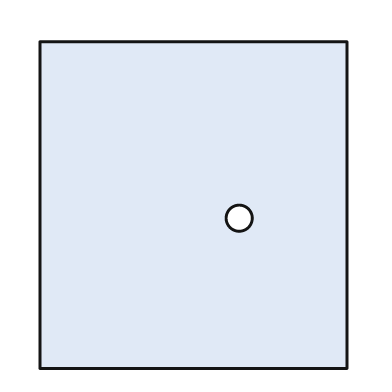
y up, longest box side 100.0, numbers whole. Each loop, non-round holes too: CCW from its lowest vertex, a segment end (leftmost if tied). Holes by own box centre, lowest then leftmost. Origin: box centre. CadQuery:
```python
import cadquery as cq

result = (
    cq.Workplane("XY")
    .moveTo(-47.0, -50.0)
    .lineTo(47.0, -50.0)
    .lineTo(47.0, 50.0)
    .lineTo(-47.0, 50.0)
    .close()
    .moveTo(14.0, -4.0)
    .circle(4.0)
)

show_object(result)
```